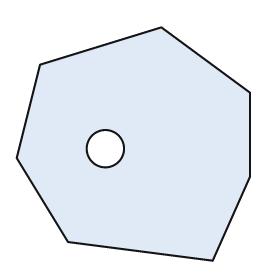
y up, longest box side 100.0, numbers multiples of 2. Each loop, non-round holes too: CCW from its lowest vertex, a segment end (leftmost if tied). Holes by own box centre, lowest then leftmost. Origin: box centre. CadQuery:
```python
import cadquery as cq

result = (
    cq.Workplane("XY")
    .moveTo(34.0, -50.0)
    .lineTo(50.0, -14.0)
    .lineTo(50.0, 22.0)
    .lineTo(12.0, 50.0)
    .lineTo(-40.0, 34.0)
    .lineTo(-50.0, -6.0)
    .lineTo(-28.0, -42.0)
    .close()
    .moveTo(-12.0, -2.0)
    .circle(8.0)
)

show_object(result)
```